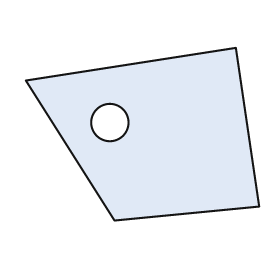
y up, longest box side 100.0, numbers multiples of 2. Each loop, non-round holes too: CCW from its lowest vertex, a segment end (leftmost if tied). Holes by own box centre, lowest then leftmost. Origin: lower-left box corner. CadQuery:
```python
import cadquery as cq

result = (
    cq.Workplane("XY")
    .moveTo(38.0, 0.0)
    .lineTo(100.0, 6.0)
    .lineTo(90.0, 74.0)
    .lineTo(0.0, 60.0)
    .close()
    .moveTo(36.0, 42.0)
    .circle(8.0)
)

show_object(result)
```